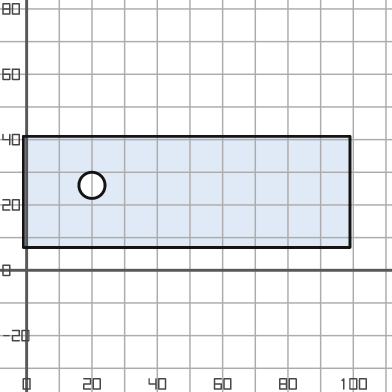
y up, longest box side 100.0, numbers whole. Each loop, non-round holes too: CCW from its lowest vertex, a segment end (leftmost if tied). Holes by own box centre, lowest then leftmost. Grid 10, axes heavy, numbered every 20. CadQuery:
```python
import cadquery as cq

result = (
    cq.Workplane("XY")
    .moveTo(-1.0, 7.0)
    .lineTo(99.0, 7.0)
    .lineTo(99.0, 41.0)
    .lineTo(-1.0, 41.0)
    .close()
    .moveTo(20.0, 26.0)
    .circle(4.0)
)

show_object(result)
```